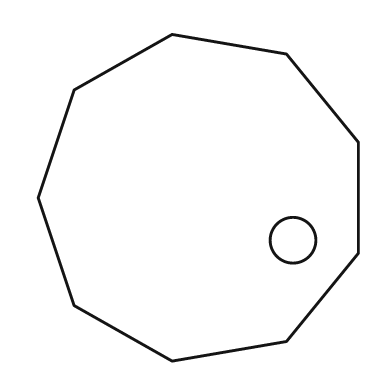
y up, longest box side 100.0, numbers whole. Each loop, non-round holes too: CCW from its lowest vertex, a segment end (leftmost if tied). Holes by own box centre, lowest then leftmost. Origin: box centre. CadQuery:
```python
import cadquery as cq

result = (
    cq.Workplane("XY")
    .moveTo(-8.0, -50.0)
    .lineTo(27.0, -44.0)
    .lineTo(49.0, -17.0)
    .lineTo(49.0, 17.0)
    .lineTo(27.0, 44.0)
    .lineTo(-8.0, 50.0)
    .lineTo(-38.0, 33.0)
    .lineTo(-49.0, 0.0)
    .lineTo(-38.0, -33.0)
    .close()
    .moveTo(29.0, -13.0)
    .circle(7.0)
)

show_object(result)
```